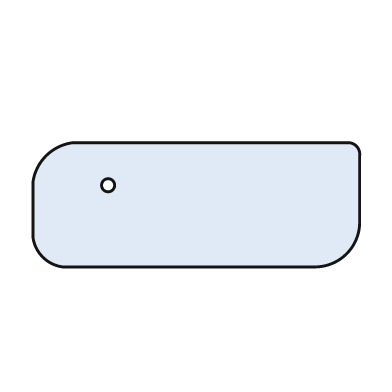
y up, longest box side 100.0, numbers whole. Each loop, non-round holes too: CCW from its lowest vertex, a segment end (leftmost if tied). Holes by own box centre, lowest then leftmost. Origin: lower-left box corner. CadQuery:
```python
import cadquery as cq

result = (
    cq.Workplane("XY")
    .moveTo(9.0, 0.0)
    .lineTo(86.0, 0.0)
    .threePointArc((96.0, 4.0), (100.0, 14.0))
    .lineTo(100.0, 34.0)
    .threePointArc((99.0, 37.0), (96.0, 38.0))
    .lineTo(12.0, 38.0)
    .threePointArc((4.0, 34.0), (0.0, 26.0))
    .lineTo(0.0, 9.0)
    .threePointArc((3.0, 3.0), (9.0, 0.0))
    .close()
    .moveTo(23.0, 25.0)
    .circle(2.0)
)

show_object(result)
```